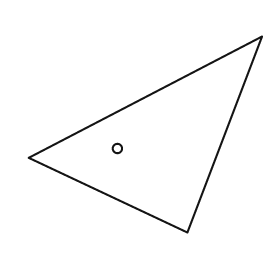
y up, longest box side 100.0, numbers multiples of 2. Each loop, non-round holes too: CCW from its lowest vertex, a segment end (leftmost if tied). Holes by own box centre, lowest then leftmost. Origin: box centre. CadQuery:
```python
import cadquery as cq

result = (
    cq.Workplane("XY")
    .moveTo(18.0, -42.0)
    .lineTo(50.0, 42.0)
    .lineTo(-50.0, -10.0)
    .close()
    .moveTo(-12.0, -6.0)
    .circle(2.0)
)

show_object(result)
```